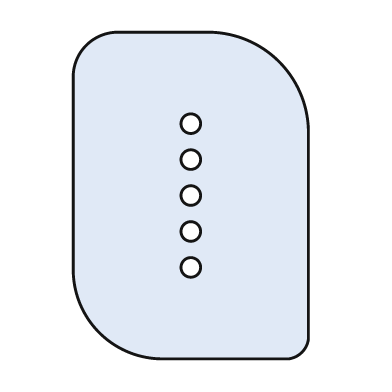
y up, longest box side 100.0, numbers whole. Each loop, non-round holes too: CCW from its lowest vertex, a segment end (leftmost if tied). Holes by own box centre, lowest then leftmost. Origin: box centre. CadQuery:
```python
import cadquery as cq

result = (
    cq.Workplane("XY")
    .moveTo(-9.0, -50.0)
    .lineTo(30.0, -50.0)
    .threePointArc((34.0, -48.0), (36.0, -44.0))
    .lineTo(36.0, 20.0)
    .threePointArc((27.0, 41.0), (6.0, 50.0))
    .lineTo(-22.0, 50.0)
    .threePointArc((-32.0, 46.0), (-36.0, 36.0))
    .lineTo(-36.0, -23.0)
    .threePointArc((-28.0, -42.0), (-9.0, -50.0))
    .close()
    .moveTo(0.0, -22.0)
    .circle(3.0)
    .moveTo(0.0, -11.0)
    .circle(3.0)
    .moveTo(0.0, 0.0)
    .circle(3.0)
    .moveTo(0.0, 11.0)
    .circle(3.0)
    .moveTo(0.0, 22.0)
    .circle(3.0)
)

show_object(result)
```